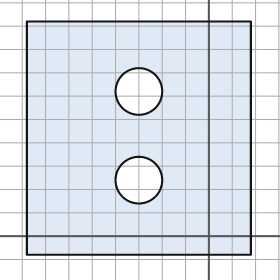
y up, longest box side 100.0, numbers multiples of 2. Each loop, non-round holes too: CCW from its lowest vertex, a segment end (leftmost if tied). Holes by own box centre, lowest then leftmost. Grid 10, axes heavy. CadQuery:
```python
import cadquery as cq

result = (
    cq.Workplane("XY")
    .moveTo(-78.0, -8.0)
    .lineTo(18.0, -8.0)
    .lineTo(18.0, 92.0)
    .lineTo(-78.0, 92.0)
    .close()
    .moveTo(-30.0, 24.0)
    .circle(10.0)
    .moveTo(-30.0, 62.0)
    .circle(10.0)
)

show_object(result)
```